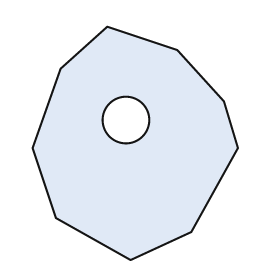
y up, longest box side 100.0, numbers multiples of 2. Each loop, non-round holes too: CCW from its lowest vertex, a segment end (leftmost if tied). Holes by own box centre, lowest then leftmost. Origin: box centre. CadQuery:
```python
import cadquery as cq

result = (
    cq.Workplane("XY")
    .moveTo(-2.0, -50.0)
    .lineTo(24.0, -38.0)
    .lineTo(44.0, -2.0)
    .lineTo(38.0, 18.0)
    .lineTo(18.0, 40.0)
    .lineTo(-12.0, 50.0)
    .lineTo(-32.0, 32.0)
    .lineTo(-44.0, -2.0)
    .lineTo(-34.0, -32.0)
    .close()
    .moveTo(-4.0, 10.0)
    .circle(10.0)
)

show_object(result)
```